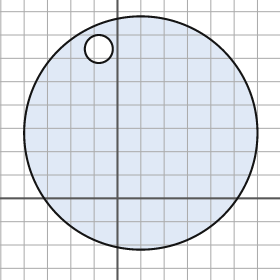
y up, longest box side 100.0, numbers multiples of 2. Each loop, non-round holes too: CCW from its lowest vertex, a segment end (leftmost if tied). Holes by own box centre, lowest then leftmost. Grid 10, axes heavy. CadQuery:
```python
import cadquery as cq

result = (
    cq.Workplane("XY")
    .moveTo(10.0, 28.0)
    .circle(50.0)
    .moveTo(-8.0, 64.0)
    .circle(6.0)
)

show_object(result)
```